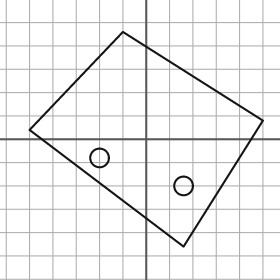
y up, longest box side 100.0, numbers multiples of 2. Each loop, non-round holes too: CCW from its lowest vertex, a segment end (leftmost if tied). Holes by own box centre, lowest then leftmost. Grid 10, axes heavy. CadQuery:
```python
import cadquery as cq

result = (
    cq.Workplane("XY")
    .moveTo(16.0, -46.0)
    .lineTo(50.0, 8.0)
    .lineTo(-10.0, 46.0)
    .lineTo(-50.0, 4.0)
    .close()
    .moveTo(16.0, -20.0)
    .circle(4.0)
    .moveTo(-20.0, -8.0)
    .circle(4.0)
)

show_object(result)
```